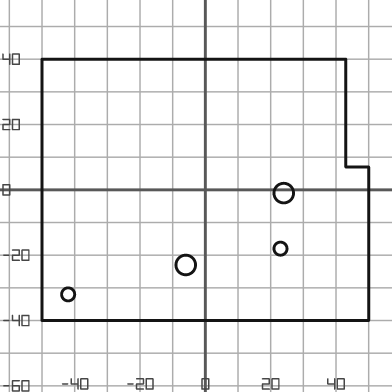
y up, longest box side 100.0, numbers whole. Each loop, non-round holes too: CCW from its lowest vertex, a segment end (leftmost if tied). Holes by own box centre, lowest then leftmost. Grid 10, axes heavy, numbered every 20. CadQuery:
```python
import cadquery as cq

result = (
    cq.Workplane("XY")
    .moveTo(-50.0, -40.0)
    .lineTo(50.0, -40.0)
    .lineTo(50.0, 7.0)
    .lineTo(43.0, 7.0)
    .lineTo(43.0, 40.0)
    .lineTo(-50.0, 40.0)
    .close()
    .moveTo(-42.0, -32.0)
    .circle(2.0)
    .moveTo(-6.0, -23.0)
    .circle(3.0)
    .moveTo(23.0, -18.0)
    .circle(2.0)
    .moveTo(24.0, -1.0)
    .circle(3.0)
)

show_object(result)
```